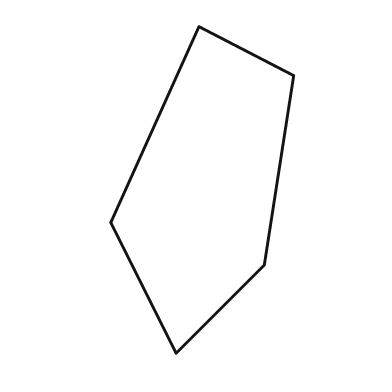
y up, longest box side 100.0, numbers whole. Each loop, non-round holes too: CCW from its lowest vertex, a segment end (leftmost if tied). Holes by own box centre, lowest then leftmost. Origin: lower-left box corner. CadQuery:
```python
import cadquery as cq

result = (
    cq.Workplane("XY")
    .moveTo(20.0, 0.0)
    .lineTo(47.0, 27.0)
    .lineTo(56.0, 85.0)
    .lineTo(27.0, 100.0)
    .lineTo(0.0, 40.0)
    .close()
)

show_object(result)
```